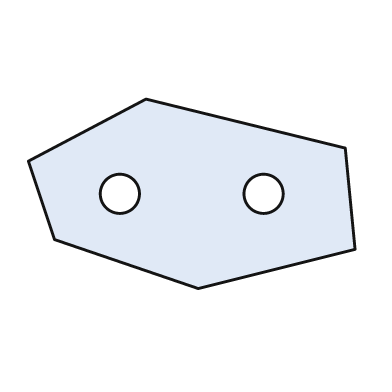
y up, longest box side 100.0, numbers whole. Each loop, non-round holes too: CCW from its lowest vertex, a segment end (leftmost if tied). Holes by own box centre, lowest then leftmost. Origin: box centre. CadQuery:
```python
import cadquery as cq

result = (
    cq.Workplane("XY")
    .moveTo(2.0, -29.0)
    .lineTo(50.0, -17.0)
    .lineTo(47.0, 14.0)
    .lineTo(-14.0, 29.0)
    .lineTo(-50.0, 10.0)
    .lineTo(-42.0, -14.0)
    .close()
    .moveTo(-22.0, 0.0)
    .circle(6.0)
    .moveTo(22.0, 0.0)
    .circle(6.0)
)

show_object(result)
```